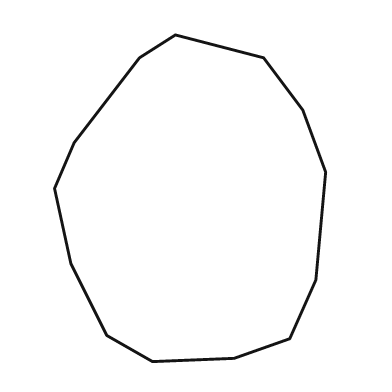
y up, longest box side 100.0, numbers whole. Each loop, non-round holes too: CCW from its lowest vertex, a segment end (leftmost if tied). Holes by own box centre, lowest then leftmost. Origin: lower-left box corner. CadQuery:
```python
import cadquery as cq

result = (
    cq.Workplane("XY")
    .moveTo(30.0, 0.0)
    .lineTo(55.0, 1.0)
    .lineTo(72.0, 7.0)
    .lineTo(80.0, 25.0)
    .lineTo(83.0, 58.0)
    .lineTo(76.0, 77.0)
    .lineTo(64.0, 93.0)
    .lineTo(37.0, 100.0)
    .lineTo(26.0, 93.0)
    .lineTo(6.0, 67.0)
    .lineTo(0.0, 53.0)
    .lineTo(5.0, 30.0)
    .lineTo(16.0, 8.0)
    .close()
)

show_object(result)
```